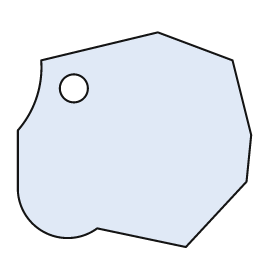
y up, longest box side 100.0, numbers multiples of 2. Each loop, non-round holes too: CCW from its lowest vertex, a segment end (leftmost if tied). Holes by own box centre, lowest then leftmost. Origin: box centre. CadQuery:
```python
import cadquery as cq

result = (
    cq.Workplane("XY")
    .moveTo(22.0, -46.0)
    .lineTo(48.0, -18.0)
    .lineTo(50.0, 2.0)
    .lineTo(42.0, 34.0)
    .lineTo(10.0, 46.0)
    .lineTo(-40.0, 34.0)
    .threePointArc((-42.0, 18.0), (-50.0, 4.0))
    .lineTo(-50.0, -22.0)
    .threePointArc((-38.0, -40.0), (-16.0, -38.0))
    .close()
    .moveTo(-26.0, 22.0)
    .circle(6.0)
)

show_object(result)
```